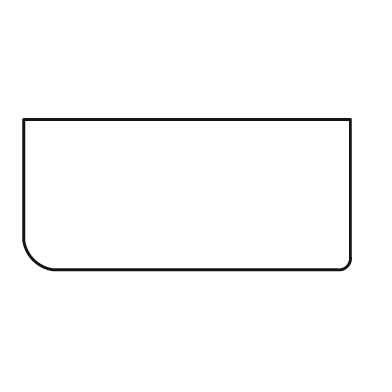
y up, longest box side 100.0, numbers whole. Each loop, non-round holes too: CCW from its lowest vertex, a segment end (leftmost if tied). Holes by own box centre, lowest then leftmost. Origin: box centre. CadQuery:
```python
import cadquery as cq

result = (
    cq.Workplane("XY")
    .moveTo(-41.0, -23.0)
    .lineTo(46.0, -23.0)
    .threePointArc((49.0, -22.0), (50.0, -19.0))
    .lineTo(50.0, 23.0)
    .lineTo(-50.0, 23.0)
    .lineTo(-50.0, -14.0)
    .threePointArc((-47.0, -20.0), (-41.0, -23.0))
    .close()
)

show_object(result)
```